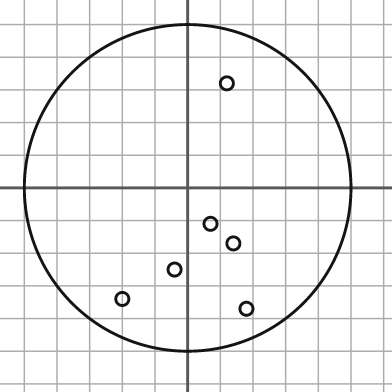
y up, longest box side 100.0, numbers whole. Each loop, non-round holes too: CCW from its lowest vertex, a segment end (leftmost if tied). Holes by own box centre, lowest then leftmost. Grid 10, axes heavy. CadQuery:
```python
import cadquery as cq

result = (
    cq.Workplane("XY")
    .moveTo(0.0, 0.0)
    .circle(50.0)
    .moveTo(18.0, -37.0)
    .circle(2.0)
    .moveTo(-20.0, -34.0)
    .circle(2.0)
    .moveTo(-4.0, -25.0)
    .circle(2.0)
    .moveTo(14.0, -17.0)
    .circle(2.0)
    .moveTo(7.0, -11.0)
    .circle(2.0)
    .moveTo(12.0, 32.0)
    .circle(2.0)
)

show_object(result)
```